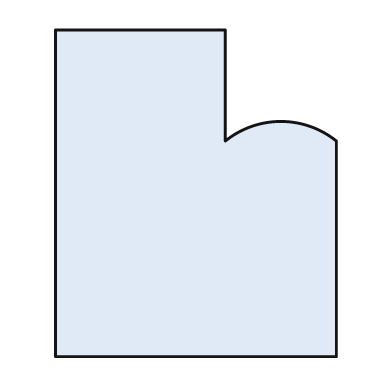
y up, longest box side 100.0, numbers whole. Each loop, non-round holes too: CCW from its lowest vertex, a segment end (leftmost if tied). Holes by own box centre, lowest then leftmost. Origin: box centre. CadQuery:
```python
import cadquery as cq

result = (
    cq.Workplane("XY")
    .moveTo(-43.0, -50.0)
    .lineTo(43.0, -50.0)
    .lineTo(43.0, 16.0)
    .threePointArc((26.0, 22.0), (9.0, 16.0))
    .lineTo(9.0, 50.0)
    .lineTo(-43.0, 50.0)
    .close()
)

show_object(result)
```